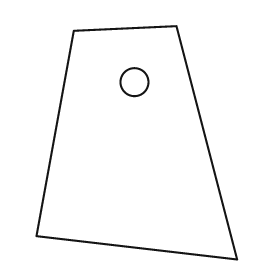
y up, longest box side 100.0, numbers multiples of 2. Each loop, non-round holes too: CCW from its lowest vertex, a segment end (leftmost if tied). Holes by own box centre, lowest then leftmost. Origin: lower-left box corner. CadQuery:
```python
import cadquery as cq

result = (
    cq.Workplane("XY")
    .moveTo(86.0, 0.0)
    .lineTo(60.0, 100.0)
    .lineTo(16.0, 98.0)
    .lineTo(0.0, 10.0)
    .close()
    .moveTo(42.0, 76.0)
    .circle(6.0)
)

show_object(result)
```